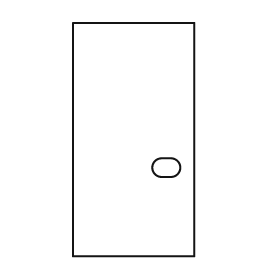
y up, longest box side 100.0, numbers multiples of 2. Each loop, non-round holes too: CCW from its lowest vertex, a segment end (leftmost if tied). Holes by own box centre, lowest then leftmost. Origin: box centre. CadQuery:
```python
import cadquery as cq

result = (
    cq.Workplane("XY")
    .moveTo(-26.0, -50.0)
    .lineTo(26.0, -50.0)
    .lineTo(26.0, 50.0)
    .lineTo(-26.0, 50.0)
    .close()
    .moveTo(12.0, -16.0)
    .lineTo(16.0, -16.0)
    .threePointArc((20.0, -12.0), (16.0, -8.0))
    .lineTo(12.0, -8.0)
    .threePointArc((8.0, -12.0), (12.0, -16.0))
    .close()
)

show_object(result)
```